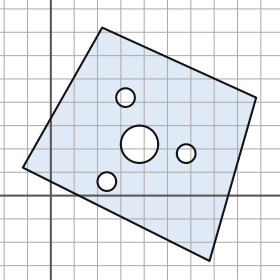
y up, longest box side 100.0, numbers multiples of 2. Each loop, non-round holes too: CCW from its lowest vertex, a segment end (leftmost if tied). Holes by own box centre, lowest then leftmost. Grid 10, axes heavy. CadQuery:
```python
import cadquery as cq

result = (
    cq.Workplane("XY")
    .moveTo(68.0, -28.0)
    .lineTo(88.0, 42.0)
    .lineTo(22.0, 72.0)
    .lineTo(-12.0, 12.0)
    .close()
    .moveTo(24.0, 6.0)
    .circle(4.0)
    .moveTo(58.0, 18.0)
    .circle(4.0)
    .moveTo(38.0, 22.0)
    .circle(8.0)
    .moveTo(32.0, 42.0)
    .circle(4.0)
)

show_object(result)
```